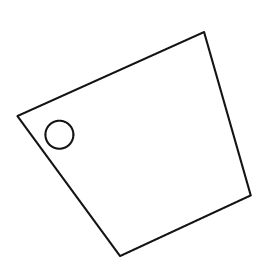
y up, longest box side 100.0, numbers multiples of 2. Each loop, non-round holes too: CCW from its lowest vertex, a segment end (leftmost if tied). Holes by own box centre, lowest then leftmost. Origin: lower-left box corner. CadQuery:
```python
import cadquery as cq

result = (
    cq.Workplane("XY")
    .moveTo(44.0, 0.0)
    .lineTo(100.0, 26.0)
    .lineTo(80.0, 96.0)
    .lineTo(0.0, 60.0)
    .close()
    .moveTo(18.0, 52.0)
    .circle(6.0)
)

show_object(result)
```